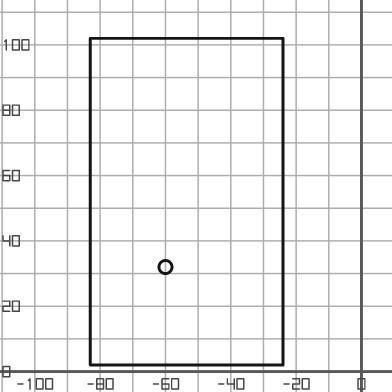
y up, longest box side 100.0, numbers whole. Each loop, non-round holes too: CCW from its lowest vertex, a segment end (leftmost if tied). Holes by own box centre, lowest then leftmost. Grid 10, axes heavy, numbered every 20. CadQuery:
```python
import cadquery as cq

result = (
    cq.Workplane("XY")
    .moveTo(-83.0, 2.0)
    .lineTo(-24.0, 2.0)
    .lineTo(-24.0, 102.0)
    .lineTo(-83.0, 102.0)
    .close()
    .moveTo(-60.0, 32.0)
    .circle(2.0)
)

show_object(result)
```